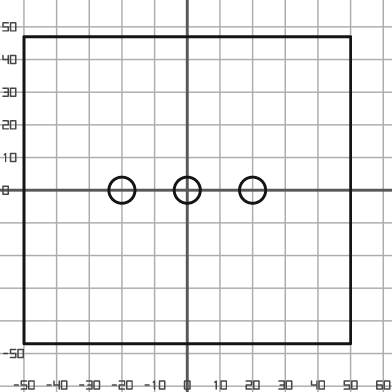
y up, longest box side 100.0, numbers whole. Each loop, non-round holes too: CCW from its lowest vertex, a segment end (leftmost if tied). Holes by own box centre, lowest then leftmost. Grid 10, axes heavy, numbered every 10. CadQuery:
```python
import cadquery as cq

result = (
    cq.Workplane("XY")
    .moveTo(-50.0, -47.0)
    .lineTo(50.0, -47.0)
    .lineTo(50.0, 47.0)
    .lineTo(-50.0, 47.0)
    .close()
    .moveTo(-20.0, 0.0)
    .circle(4.0)
    .moveTo(0.0, 0.0)
    .circle(4.0)
    .moveTo(20.0, 0.0)
    .circle(4.0)
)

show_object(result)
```